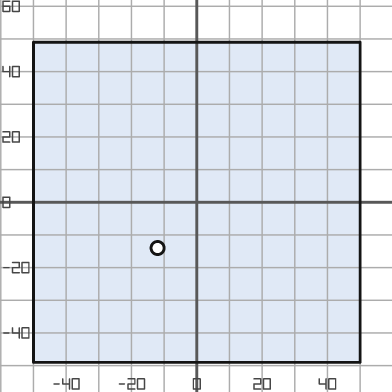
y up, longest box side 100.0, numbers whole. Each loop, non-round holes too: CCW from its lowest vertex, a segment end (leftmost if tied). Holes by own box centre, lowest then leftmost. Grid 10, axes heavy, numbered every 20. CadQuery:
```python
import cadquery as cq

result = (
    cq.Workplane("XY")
    .moveTo(-50.0, -49.0)
    .lineTo(50.0, -49.0)
    .lineTo(50.0, 49.0)
    .lineTo(-50.0, 49.0)
    .close()
    .moveTo(-12.0, -14.0)
    .circle(2.0)
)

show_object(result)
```